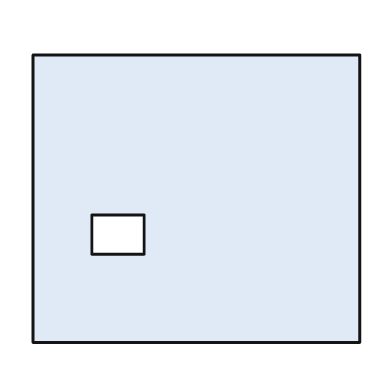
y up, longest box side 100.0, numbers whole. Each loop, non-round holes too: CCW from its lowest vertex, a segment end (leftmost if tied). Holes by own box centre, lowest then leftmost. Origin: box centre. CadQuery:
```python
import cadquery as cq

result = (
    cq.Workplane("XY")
    .moveTo(-50.0, -44.0)
    .lineTo(50.0, -44.0)
    .lineTo(50.0, 44.0)
    .lineTo(-50.0, 44.0)
    .close()
    .moveTo(-32.0, -17.0)
    .lineTo(-16.0, -17.0)
    .lineTo(-16.0, -5.0)
    .lineTo(-32.0, -5.0)
    .close()
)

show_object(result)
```